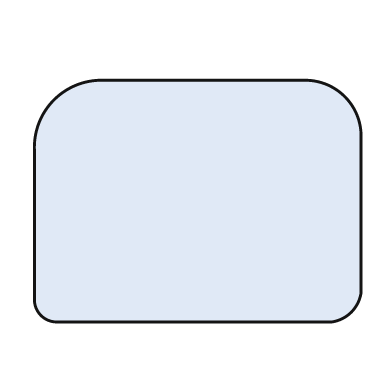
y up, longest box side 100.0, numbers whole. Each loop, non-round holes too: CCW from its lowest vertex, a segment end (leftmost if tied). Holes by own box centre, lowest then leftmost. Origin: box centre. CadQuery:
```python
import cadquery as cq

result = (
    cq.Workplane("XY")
    .moveTo(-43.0, -37.0)
    .lineTo(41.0, -37.0)
    .threePointArc((47.0, -34.0), (50.0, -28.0))
    .lineTo(50.0, 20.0)
    .threePointArc((45.0, 32.0), (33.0, 37.0))
    .lineTo(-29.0, 37.0)
    .threePointArc((-44.0, 31.0), (-50.0, 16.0))
    .lineTo(-50.0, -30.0)
    .threePointArc((-48.0, -35.0), (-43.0, -37.0))
    .close()
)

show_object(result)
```